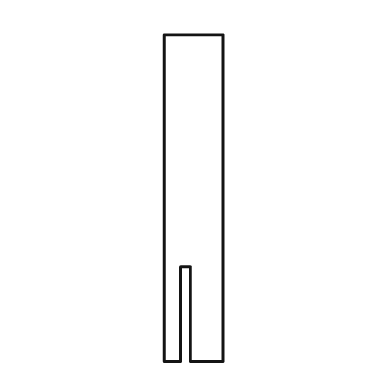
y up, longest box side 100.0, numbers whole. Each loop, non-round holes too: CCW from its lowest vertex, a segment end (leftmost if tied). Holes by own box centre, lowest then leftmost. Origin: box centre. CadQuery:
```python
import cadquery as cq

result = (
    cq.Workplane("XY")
    .moveTo(-9.0, -50.0)
    .lineTo(-4.0, -50.0)
    .lineTo(-4.0, -21.0)
    .lineTo(-1.0, -21.0)
    .lineTo(-1.0, -50.0)
    .lineTo(9.0, -50.0)
    .lineTo(9.0, 50.0)
    .lineTo(-9.0, 50.0)
    .close()
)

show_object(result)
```